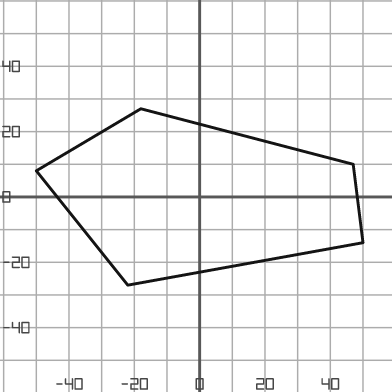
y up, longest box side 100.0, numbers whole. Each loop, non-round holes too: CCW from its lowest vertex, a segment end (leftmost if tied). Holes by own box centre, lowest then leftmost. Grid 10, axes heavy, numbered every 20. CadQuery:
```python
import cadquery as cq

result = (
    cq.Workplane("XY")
    .moveTo(-22.0, -27.0)
    .lineTo(50.0, -14.0)
    .lineTo(47.0, 10.0)
    .lineTo(-18.0, 27.0)
    .lineTo(-50.0, 8.0)
    .close()
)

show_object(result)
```